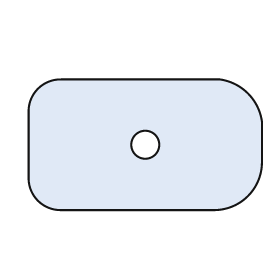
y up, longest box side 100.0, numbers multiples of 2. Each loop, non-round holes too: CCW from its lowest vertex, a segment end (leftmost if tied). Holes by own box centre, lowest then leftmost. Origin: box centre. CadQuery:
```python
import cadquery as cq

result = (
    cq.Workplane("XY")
    .moveTo(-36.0, -28.0)
    .lineTo(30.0, -28.0)
    .threePointArc((44.0, -22.0), (50.0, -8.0))
    .lineTo(50.0, 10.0)
    .threePointArc((44.0, 22.0), (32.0, 28.0))
    .lineTo(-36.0, 28.0)
    .threePointArc((-46.0, 24.0), (-50.0, 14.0))
    .lineTo(-50.0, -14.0)
    .threePointArc((-46.0, -24.0), (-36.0, -28.0))
    .close()
    .moveTo(0.0, 0.0)
    .circle(6.0)
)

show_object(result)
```